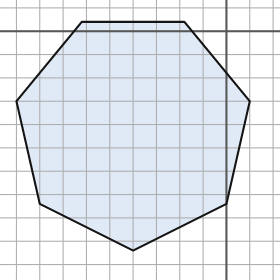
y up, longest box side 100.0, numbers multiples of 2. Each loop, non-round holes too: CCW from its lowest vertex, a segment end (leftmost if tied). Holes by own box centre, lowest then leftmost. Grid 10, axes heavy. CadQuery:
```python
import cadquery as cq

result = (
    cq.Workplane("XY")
    .moveTo(-40.0, -94.0)
    .lineTo(0.0, -74.0)
    .lineTo(10.0, -30.0)
    .lineTo(-18.0, 4.0)
    .lineTo(-62.0, 4.0)
    .lineTo(-90.0, -30.0)
    .lineTo(-80.0, -74.0)
    .close()
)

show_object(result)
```